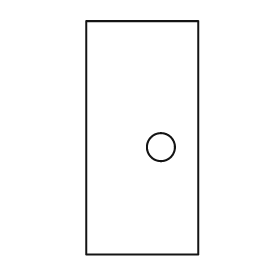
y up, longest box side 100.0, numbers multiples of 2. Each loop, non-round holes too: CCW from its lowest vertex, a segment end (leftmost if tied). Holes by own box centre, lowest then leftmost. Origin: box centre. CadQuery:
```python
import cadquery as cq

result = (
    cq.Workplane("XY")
    .moveTo(-24.0, -50.0)
    .lineTo(24.0, -50.0)
    .lineTo(24.0, 50.0)
    .lineTo(-24.0, 50.0)
    .close()
    .moveTo(8.0, -4.0)
    .circle(6.0)
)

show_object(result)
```